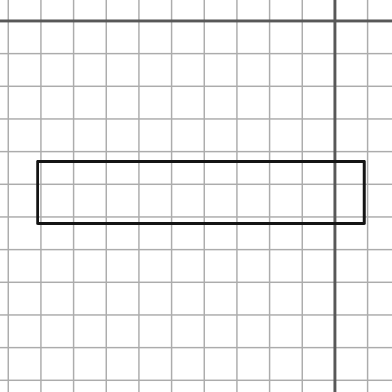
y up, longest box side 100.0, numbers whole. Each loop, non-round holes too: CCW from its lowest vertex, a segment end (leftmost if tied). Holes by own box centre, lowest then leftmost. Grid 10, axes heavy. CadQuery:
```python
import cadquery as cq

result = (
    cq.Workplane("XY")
    .moveTo(-91.0, -62.0)
    .lineTo(9.0, -62.0)
    .lineTo(9.0, -43.0)
    .lineTo(-91.0, -43.0)
    .close()
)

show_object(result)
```